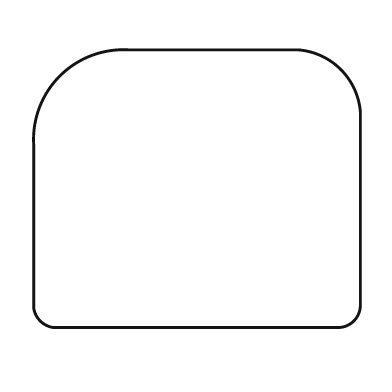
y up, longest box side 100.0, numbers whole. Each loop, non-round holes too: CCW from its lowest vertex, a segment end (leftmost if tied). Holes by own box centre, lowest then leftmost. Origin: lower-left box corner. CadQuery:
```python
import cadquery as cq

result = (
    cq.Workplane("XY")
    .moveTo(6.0, 0.0)
    .lineTo(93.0, 0.0)
    .threePointArc((98.0, 2.0), (100.0, 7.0))
    .lineTo(100.0, 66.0)
    .threePointArc((94.0, 79.0), (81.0, 85.0))
    .lineTo(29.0, 85.0)
    .threePointArc((8.0, 77.0), (0.0, 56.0))
    .lineTo(0.0, 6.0)
    .threePointArc((2.0, 2.0), (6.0, 0.0))
    .close()
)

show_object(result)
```